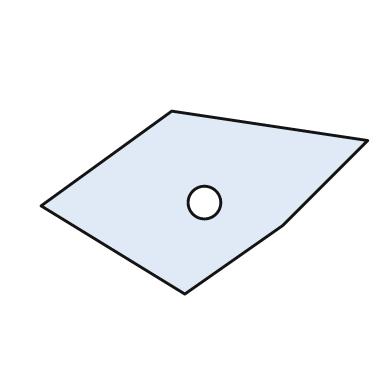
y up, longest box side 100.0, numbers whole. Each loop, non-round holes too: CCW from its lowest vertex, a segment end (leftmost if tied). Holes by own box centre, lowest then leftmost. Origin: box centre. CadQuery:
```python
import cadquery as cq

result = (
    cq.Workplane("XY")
    .moveTo(-6.0, -28.0)
    .lineTo(24.0, -7.0)
    .lineTo(50.0, 19.0)
    .lineTo(-10.0, 28.0)
    .lineTo(-50.0, -1.0)
    .close()
    .moveTo(0.0, 0.0)
    .circle(5.0)
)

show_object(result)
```